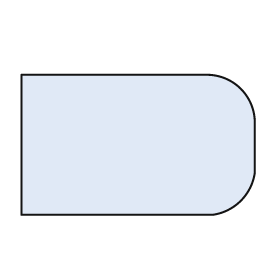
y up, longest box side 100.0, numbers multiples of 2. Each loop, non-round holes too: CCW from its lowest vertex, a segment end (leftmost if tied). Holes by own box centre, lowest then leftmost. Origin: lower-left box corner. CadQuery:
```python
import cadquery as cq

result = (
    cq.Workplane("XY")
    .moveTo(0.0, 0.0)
    .lineTo(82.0, 0.0)
    .threePointArc((94.0, 6.0), (100.0, 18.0))
    .lineTo(100.0, 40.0)
    .threePointArc((94.0, 54.0), (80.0, 60.0))
    .lineTo(0.0, 60.0)
    .close()
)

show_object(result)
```